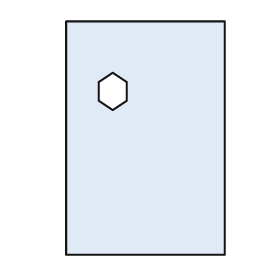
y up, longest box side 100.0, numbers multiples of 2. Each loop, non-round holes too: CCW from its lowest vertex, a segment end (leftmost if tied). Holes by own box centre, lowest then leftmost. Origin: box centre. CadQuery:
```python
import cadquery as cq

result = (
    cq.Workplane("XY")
    .moveTo(-34.0, -50.0)
    .lineTo(34.0, -50.0)
    .lineTo(34.0, 50.0)
    .lineTo(-34.0, 50.0)
    .close()
    .moveTo(-14.0, 12.0)
    .lineTo(-8.0, 16.0)
    .lineTo(-8.0, 24.0)
    .lineTo(-14.0, 28.0)
    .lineTo(-20.0, 24.0)
    .lineTo(-20.0, 16.0)
    .close()
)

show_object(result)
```